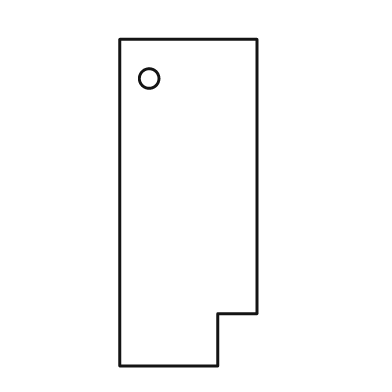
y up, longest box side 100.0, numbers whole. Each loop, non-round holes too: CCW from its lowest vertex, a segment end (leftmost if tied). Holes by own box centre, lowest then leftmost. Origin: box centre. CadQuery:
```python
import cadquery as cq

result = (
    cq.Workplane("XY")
    .moveTo(-21.0, -50.0)
    .lineTo(9.0, -50.0)
    .lineTo(9.0, -34.0)
    .lineTo(21.0, -34.0)
    .lineTo(21.0, 50.0)
    .lineTo(-21.0, 50.0)
    .close()
    .moveTo(-12.0, 38.0)
    .circle(3.0)
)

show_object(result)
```